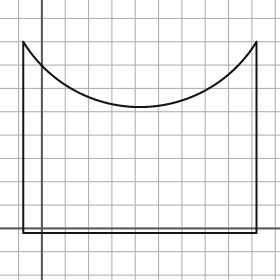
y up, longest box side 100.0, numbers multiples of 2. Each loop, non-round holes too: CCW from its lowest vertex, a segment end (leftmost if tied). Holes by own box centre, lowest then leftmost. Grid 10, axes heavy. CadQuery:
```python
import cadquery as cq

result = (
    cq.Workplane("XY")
    .moveTo(-8.0, -2.0)
    .lineTo(92.0, -2.0)
    .lineTo(92.0, 80.0)
    .threePointArc((42.0, 52.0), (-8.0, 80.0))
    .close()
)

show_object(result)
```